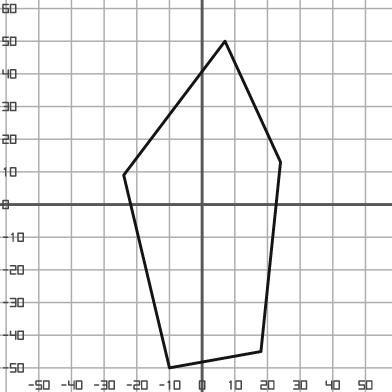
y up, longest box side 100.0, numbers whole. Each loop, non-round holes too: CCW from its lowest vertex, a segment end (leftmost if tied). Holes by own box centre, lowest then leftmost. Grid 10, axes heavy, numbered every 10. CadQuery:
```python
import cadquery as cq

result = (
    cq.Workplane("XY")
    .moveTo(-10.0, -50.0)
    .lineTo(18.0, -45.0)
    .lineTo(24.0, 13.0)
    .lineTo(7.0, 50.0)
    .lineTo(-24.0, 9.0)
    .close()
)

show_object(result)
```